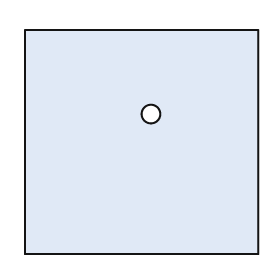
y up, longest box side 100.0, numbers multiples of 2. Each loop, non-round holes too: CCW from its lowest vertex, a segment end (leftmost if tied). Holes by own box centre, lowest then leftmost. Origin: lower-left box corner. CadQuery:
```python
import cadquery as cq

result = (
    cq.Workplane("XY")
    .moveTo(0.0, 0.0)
    .lineTo(100.0, 0.0)
    .lineTo(100.0, 96.0)
    .lineTo(0.0, 96.0)
    .close()
    .moveTo(54.0, 60.0)
    .circle(4.0)
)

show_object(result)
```